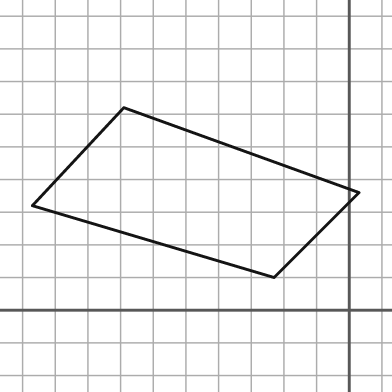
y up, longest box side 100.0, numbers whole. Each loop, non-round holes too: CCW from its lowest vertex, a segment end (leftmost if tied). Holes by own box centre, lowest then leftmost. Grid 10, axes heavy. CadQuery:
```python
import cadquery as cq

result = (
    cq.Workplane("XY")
    .moveTo(-23.0, 10.0)
    .lineTo(3.0, 36.0)
    .lineTo(-69.0, 62.0)
    .lineTo(-97.0, 32.0)
    .close()
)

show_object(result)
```